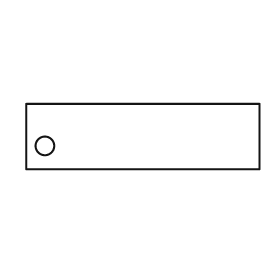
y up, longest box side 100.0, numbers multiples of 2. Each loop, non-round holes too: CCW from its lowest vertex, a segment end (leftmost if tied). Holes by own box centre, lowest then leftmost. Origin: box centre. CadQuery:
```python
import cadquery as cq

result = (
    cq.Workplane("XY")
    .moveTo(-50.0, -14.0)
    .lineTo(50.0, -14.0)
    .lineTo(50.0, 14.0)
    .lineTo(-50.0, 14.0)
    .close()
    .moveTo(-42.0, -4.0)
    .circle(4.0)
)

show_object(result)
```